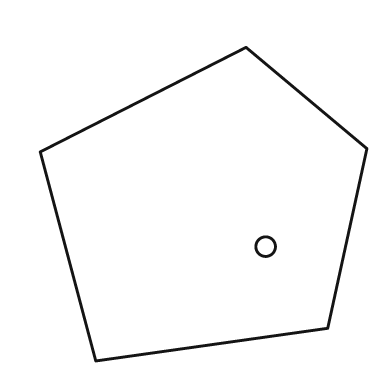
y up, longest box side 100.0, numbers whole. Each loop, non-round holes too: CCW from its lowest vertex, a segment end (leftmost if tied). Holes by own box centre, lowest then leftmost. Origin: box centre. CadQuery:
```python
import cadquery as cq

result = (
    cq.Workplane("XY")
    .moveTo(-33.0, -48.0)
    .lineTo(38.0, -38.0)
    .lineTo(50.0, 17.0)
    .lineTo(13.0, 48.0)
    .lineTo(-50.0, 16.0)
    .close()
    .moveTo(19.0, -13.0)
    .circle(3.0)
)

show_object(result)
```